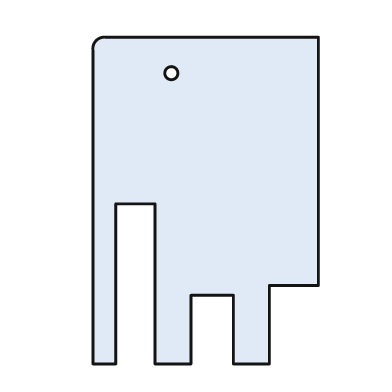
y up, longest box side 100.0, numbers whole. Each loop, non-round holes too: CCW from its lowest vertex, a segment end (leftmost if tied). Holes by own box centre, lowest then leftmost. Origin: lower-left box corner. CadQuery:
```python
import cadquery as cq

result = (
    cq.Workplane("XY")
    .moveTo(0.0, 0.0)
    .lineTo(7.0, 0.0)
    .lineTo(7.0, 49.0)
    .lineTo(19.0, 49.0)
    .lineTo(19.0, 0.0)
    .lineTo(30.0, 0.0)
    .lineTo(30.0, 21.0)
    .lineTo(43.0, 21.0)
    .lineTo(43.0, 0.0)
    .lineTo(54.0, 0.0)
    .lineTo(54.0, 24.0)
    .lineTo(69.0, 24.0)
    .lineTo(69.0, 100.0)
    .lineTo(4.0, 100.0)
    .threePointArc((1.0, 99.0), (0.0, 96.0))
    .close()
    .moveTo(24.0, 89.0)
    .circle(2.0)
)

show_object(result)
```